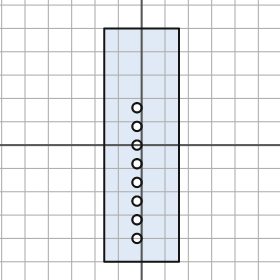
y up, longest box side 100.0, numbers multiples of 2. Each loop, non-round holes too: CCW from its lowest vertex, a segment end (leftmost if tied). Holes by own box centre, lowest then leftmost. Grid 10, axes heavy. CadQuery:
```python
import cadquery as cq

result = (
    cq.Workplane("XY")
    .moveTo(-16.0, -50.0)
    .lineTo(16.0, -50.0)
    .lineTo(16.0, 50.0)
    .lineTo(-16.0, 50.0)
    .close()
    .moveTo(-2.0, -40.0)
    .circle(2.0)
    .moveTo(-2.0, -32.0)
    .circle(2.0)
    .moveTo(-2.0, -24.0)
    .circle(2.0)
    .moveTo(-2.0, -16.0)
    .circle(2.0)
    .moveTo(-2.0, -8.0)
    .circle(2.0)
    .moveTo(-2.0, 0.0)
    .circle(2.0)
    .moveTo(-2.0, 8.0)
    .circle(2.0)
    .moveTo(-2.0, 16.0)
    .circle(2.0)
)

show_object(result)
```